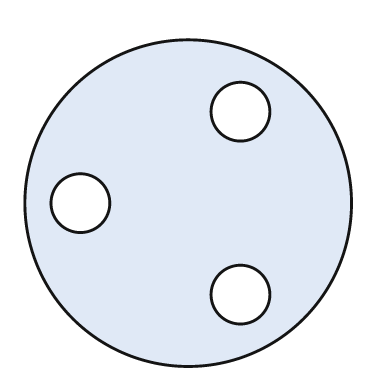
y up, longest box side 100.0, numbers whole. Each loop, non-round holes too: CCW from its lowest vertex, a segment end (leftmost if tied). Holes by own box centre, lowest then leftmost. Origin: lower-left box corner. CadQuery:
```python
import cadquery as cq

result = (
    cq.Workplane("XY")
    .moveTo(50.0, 50.0)
    .circle(50.0)
    .moveTo(66.0, 22.0)
    .circle(9.0)
    .moveTo(17.0, 50.0)
    .circle(9.0)
    .moveTo(66.0, 78.0)
    .circle(9.0)
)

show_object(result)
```